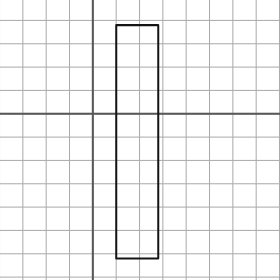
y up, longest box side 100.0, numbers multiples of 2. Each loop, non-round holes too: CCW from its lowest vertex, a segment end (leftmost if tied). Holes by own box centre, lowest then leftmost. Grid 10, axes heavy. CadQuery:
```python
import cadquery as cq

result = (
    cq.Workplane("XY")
    .moveTo(10.0, -62.0)
    .lineTo(28.0, -62.0)
    .lineTo(28.0, 38.0)
    .lineTo(10.0, 38.0)
    .close()
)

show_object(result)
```